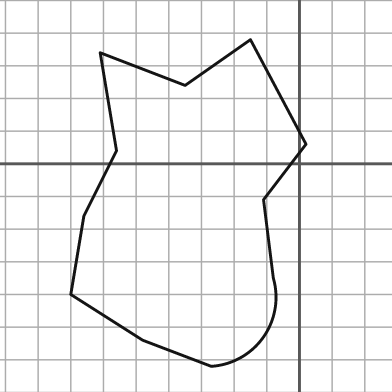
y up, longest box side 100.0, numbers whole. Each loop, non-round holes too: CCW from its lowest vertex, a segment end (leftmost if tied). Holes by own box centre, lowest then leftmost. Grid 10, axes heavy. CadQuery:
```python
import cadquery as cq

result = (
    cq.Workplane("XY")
    .moveTo(-27.0, -62.0)
    .threePointArc((-11.0, -53.0), (-8.0, -35.0))
    .lineTo(-11.0, -11.0)
    .lineTo(2.0, 6.0)
    .lineTo(-15.0, 38.0)
    .lineTo(-35.0, 24.0)
    .lineTo(-61.0, 34.0)
    .lineTo(-56.0, 4.0)
    .lineTo(-66.0, -16.0)
    .lineTo(-70.0, -40.0)
    .lineTo(-48.0, -54.0)
    .close()
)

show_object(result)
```